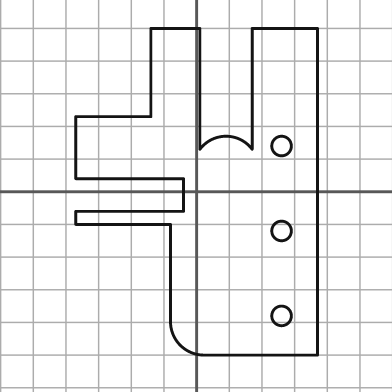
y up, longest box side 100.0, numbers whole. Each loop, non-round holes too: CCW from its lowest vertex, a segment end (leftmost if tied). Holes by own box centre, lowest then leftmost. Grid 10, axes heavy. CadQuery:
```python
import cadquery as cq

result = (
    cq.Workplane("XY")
    .moveTo(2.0, -50.0)
    .lineTo(37.0, -50.0)
    .lineTo(37.0, 50.0)
    .lineTo(17.0, 50.0)
    .lineTo(17.0, 13.0)
    .threePointArc((9.0, 17.0), (1.0, 13.0))
    .lineTo(1.0, 50.0)
    .lineTo(-14.0, 50.0)
    .lineTo(-14.0, 23.0)
    .lineTo(-37.0, 23.0)
    .lineTo(-37.0, 4.0)
    .lineTo(-4.0, 4.0)
    .lineTo(-4.0, -6.0)
    .lineTo(-37.0, -6.0)
    .lineTo(-37.0, -10.0)
    .lineTo(-8.0, -10.0)
    .lineTo(-8.0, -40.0)
    .threePointArc((-5.0, -47.0), (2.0, -50.0))
    .close()
    .moveTo(26.0, -38.0)
    .circle(3.0)
    .moveTo(26.0, -12.0)
    .circle(3.0)
    .moveTo(26.0, 14.0)
    .circle(3.0)
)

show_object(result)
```